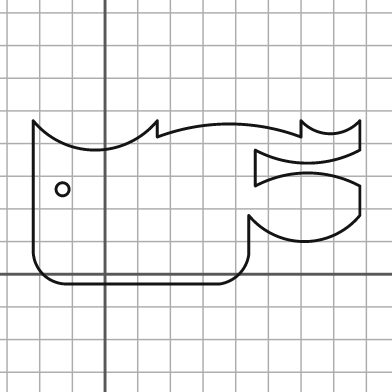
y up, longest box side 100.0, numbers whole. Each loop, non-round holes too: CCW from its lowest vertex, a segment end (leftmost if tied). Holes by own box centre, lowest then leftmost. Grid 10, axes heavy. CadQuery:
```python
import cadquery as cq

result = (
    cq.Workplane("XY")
    .moveTo(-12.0, -3.0)
    .lineTo(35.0, -3.0)
    .threePointArc((41.0, 0.0), (44.0, 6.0))
    .lineTo(44.0, 18.0)
    .threePointArc((61.0, 10.0), (78.0, 18.0))
    .lineTo(78.0, 27.0)
    .threePointArc((62.0, 31.0), (46.0, 27.0))
    .lineTo(46.0, 38.0)
    .threePointArc((62.0, 34.0), (78.0, 38.0))
    .lineTo(78.0, 47.0)
    .threePointArc((69.0, 43.0), (60.0, 47.0))
    .lineTo(60.0, 42.0)
    .threePointArc((38.0, 46.0), (16.0, 42.0))
    .lineTo(16.0, 47.0)
    .threePointArc((-3.0, 38.0), (-22.0, 47.0))
    .lineTo(-22.0, 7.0)
    .threePointArc((-19.0, 0.0), (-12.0, -3.0))
    .close()
    .moveTo(-13.0, 26.0)
    .circle(2.0)
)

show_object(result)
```